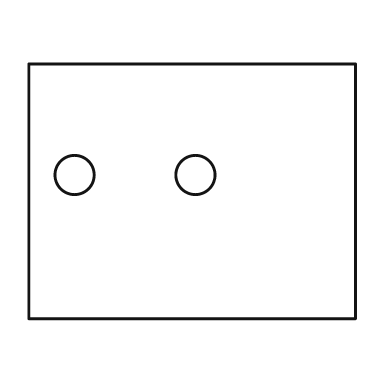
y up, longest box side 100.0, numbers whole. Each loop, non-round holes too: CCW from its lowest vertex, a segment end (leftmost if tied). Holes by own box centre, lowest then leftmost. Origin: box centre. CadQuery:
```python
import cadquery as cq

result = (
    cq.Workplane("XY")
    .moveTo(-50.0, -39.0)
    .lineTo(50.0, -39.0)
    .lineTo(50.0, 39.0)
    .lineTo(-50.0, 39.0)
    .close()
    .moveTo(-36.0, 5.0)
    .circle(6.0)
    .moveTo(1.0, 5.0)
    .circle(6.0)
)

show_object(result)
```